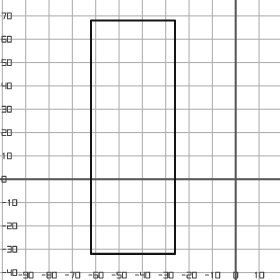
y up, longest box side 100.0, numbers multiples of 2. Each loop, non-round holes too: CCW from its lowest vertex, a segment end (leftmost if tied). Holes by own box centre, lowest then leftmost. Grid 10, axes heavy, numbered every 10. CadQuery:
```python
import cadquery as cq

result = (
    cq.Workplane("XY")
    .moveTo(-62.0, -32.0)
    .lineTo(-26.0, -32.0)
    .lineTo(-26.0, 68.0)
    .lineTo(-62.0, 68.0)
    .close()
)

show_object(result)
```